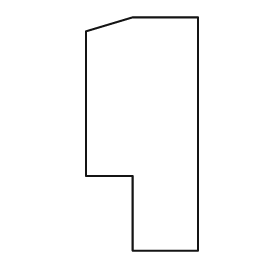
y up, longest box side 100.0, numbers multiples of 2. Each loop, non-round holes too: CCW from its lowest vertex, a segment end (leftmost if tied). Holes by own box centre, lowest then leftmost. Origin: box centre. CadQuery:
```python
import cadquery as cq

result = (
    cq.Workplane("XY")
    .moveTo(-4.0, -50.0)
    .lineTo(24.0, -50.0)
    .lineTo(24.0, 50.0)
    .lineTo(-4.0, 50.0)
    .lineTo(-24.0, 44.0)
    .lineTo(-24.0, -18.0)
    .lineTo(-4.0, -18.0)
    .close()
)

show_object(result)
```